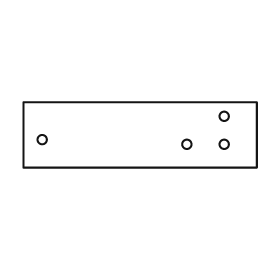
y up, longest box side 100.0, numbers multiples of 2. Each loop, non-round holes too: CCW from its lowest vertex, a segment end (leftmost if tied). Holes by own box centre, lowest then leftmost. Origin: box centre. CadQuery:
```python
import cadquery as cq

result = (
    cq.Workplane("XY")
    .moveTo(-50.0, -14.0)
    .lineTo(50.0, -14.0)
    .lineTo(50.0, 14.0)
    .lineTo(-50.0, 14.0)
    .close()
    .moveTo(20.0, -4.0)
    .circle(2.0)
    .moveTo(36.0, -4.0)
    .circle(2.0)
    .moveTo(-42.0, -2.0)
    .circle(2.0)
    .moveTo(36.0, 8.0)
    .circle(2.0)
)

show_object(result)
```